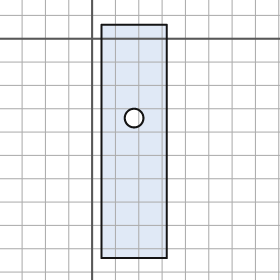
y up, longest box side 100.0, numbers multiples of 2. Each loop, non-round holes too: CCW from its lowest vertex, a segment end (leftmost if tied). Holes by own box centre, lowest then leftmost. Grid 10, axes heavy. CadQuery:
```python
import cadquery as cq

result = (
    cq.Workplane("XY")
    .moveTo(4.0, -94.0)
    .lineTo(32.0, -94.0)
    .lineTo(32.0, 6.0)
    .lineTo(4.0, 6.0)
    .close()
    .moveTo(18.0, -34.0)
    .circle(4.0)
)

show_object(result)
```